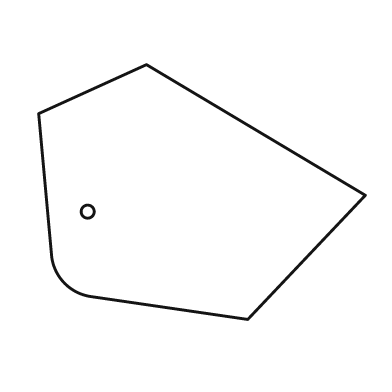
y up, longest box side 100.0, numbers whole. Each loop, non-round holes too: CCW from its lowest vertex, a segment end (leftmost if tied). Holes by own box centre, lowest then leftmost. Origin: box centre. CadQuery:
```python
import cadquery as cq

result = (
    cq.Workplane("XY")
    .moveTo(14.0, -39.0)
    .lineTo(50.0, -1.0)
    .lineTo(-17.0, 39.0)
    .lineTo(-50.0, 24.0)
    .lineTo(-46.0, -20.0)
    .threePointArc((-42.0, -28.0), (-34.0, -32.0))
    .close()
    .moveTo(-35.0, -6.0)
    .circle(2.0)
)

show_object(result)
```